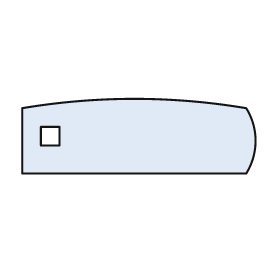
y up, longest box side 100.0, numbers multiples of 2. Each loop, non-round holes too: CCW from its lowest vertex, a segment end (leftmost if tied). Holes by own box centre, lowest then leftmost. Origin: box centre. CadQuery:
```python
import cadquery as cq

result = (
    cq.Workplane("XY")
    .moveTo(-50.0, -16.0)
    .lineTo(46.0, -16.0)
    .threePointArc((50.0, -2.0), (46.0, 12.0))
    .threePointArc((-2.0, 16.0), (-50.0, 12.0))
    .close()
    .moveTo(-42.0, -4.0)
    .lineTo(-34.0, -4.0)
    .lineTo(-34.0, 4.0)
    .lineTo(-42.0, 4.0)
    .close()
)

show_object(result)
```